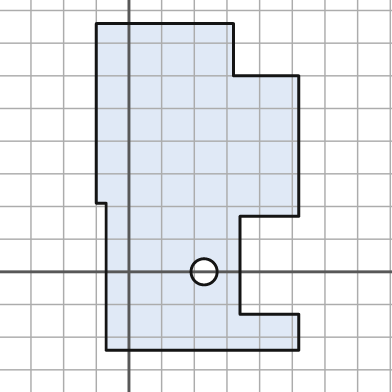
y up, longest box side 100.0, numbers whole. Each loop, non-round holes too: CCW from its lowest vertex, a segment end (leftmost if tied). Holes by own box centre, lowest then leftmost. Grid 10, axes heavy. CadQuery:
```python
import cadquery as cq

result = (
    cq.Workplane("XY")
    .moveTo(-7.0, -24.0)
    .lineTo(52.0, -24.0)
    .lineTo(52.0, -13.0)
    .lineTo(34.0, -13.0)
    .lineTo(34.0, 17.0)
    .lineTo(52.0, 17.0)
    .lineTo(52.0, 60.0)
    .lineTo(32.0, 60.0)
    .lineTo(32.0, 76.0)
    .lineTo(-10.0, 76.0)
    .lineTo(-10.0, 21.0)
    .lineTo(-7.0, 21.0)
    .close()
    .moveTo(23.0, 0.0)
    .circle(4.0)
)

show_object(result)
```